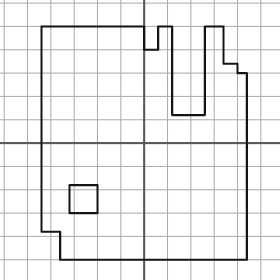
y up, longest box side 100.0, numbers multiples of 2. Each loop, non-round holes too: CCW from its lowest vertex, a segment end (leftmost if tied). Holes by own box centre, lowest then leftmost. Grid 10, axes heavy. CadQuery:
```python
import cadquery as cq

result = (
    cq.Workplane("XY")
    .moveTo(-36.0, -50.0)
    .lineTo(44.0, -50.0)
    .lineTo(44.0, 30.0)
    .lineTo(40.0, 30.0)
    .lineTo(40.0, 34.0)
    .lineTo(34.0, 34.0)
    .lineTo(34.0, 50.0)
    .lineTo(26.0, 50.0)
    .lineTo(26.0, 12.0)
    .lineTo(12.0, 12.0)
    .lineTo(12.0, 50.0)
    .lineTo(6.0, 50.0)
    .lineTo(6.0, 40.0)
    .lineTo(0.0, 40.0)
    .lineTo(0.0, 50.0)
    .lineTo(-44.0, 50.0)
    .lineTo(-44.0, -38.0)
    .lineTo(-36.0, -38.0)
    .close()
    .moveTo(-32.0, -30.0)
    .lineTo(-20.0, -30.0)
    .lineTo(-20.0, -18.0)
    .lineTo(-32.0, -18.0)
    .close()
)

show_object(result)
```